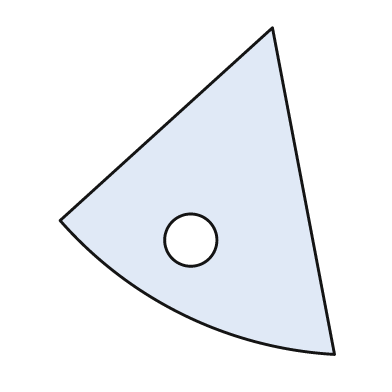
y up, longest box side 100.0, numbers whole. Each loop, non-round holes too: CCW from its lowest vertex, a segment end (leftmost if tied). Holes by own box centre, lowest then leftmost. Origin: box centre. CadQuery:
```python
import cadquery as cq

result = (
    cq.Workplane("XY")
    .moveTo(42.0, -50.0)
    .lineTo(23.0, 50.0)
    .lineTo(-42.0, -9.0)
    .threePointArc((-4.0, -38.0), (42.0, -50.0))
    .close()
    .moveTo(-2.0, -15.0)
    .circle(8.0)
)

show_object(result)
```